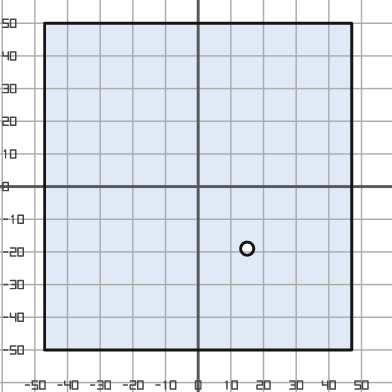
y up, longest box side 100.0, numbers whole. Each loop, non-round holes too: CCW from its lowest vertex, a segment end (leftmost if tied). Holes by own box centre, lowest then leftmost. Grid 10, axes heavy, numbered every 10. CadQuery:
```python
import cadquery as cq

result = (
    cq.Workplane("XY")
    .moveTo(-47.0, -50.0)
    .lineTo(47.0, -50.0)
    .lineTo(47.0, 50.0)
    .lineTo(-47.0, 50.0)
    .close()
    .moveTo(15.0, -19.0)
    .circle(2.0)
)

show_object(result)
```